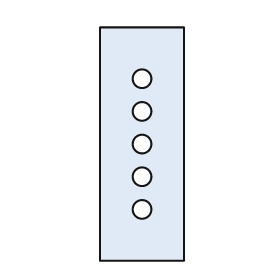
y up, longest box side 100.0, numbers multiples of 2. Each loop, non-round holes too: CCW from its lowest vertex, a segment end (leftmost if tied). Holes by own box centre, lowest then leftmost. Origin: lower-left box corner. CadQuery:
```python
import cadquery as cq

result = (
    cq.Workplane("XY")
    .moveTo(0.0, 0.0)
    .lineTo(36.0, 0.0)
    .lineTo(36.0, 100.0)
    .lineTo(0.0, 100.0)
    .close()
    .moveTo(18.0, 22.0)
    .circle(4.0)
    .moveTo(18.0, 36.0)
    .circle(4.0)
    .moveTo(18.0, 50.0)
    .circle(4.0)
    .moveTo(18.0, 64.0)
    .circle(4.0)
    .moveTo(18.0, 78.0)
    .circle(4.0)
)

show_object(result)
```